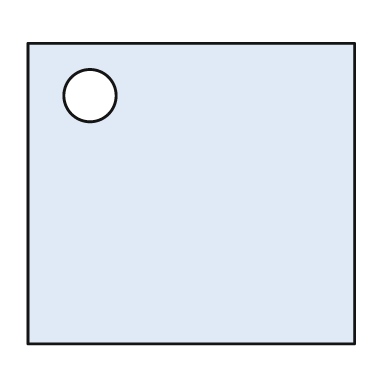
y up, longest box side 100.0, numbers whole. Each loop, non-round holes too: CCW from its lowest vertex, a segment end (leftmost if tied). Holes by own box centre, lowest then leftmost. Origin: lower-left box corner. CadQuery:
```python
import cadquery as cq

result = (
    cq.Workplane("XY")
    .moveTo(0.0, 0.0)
    .lineTo(100.0, 0.0)
    .lineTo(100.0, 92.0)
    .lineTo(0.0, 92.0)
    .close()
    .moveTo(19.0, 76.0)
    .circle(8.0)
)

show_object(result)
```